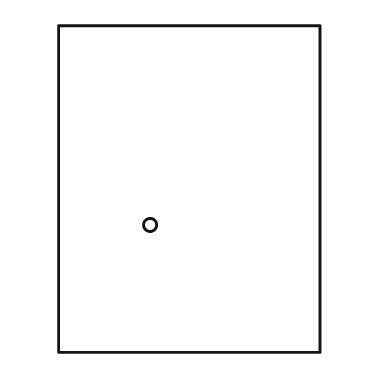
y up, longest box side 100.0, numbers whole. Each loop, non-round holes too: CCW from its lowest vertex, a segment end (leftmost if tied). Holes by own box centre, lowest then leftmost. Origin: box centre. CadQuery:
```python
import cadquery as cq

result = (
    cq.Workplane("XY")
    .moveTo(-40.0, -50.0)
    .lineTo(40.0, -50.0)
    .lineTo(40.0, 50.0)
    .lineTo(-40.0, 50.0)
    .close()
    .moveTo(-12.0, -11.0)
    .circle(2.0)
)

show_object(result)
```